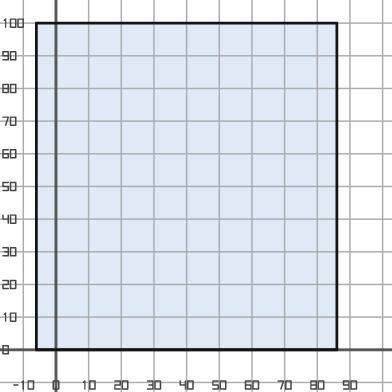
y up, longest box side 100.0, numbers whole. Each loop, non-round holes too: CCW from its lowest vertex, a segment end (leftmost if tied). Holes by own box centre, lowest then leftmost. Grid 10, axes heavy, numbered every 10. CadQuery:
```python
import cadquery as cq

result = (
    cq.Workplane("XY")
    .moveTo(-6.0, 0.0)
    .lineTo(86.0, 0.0)
    .lineTo(86.0, 100.0)
    .lineTo(-6.0, 100.0)
    .close()
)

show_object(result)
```